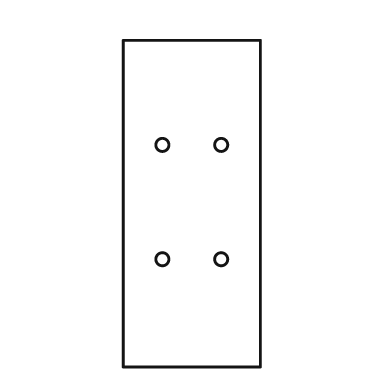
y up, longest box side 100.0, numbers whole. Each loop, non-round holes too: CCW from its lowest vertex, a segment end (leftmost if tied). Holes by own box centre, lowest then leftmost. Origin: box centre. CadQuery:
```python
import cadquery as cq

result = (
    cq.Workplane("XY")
    .moveTo(-21.0, -50.0)
    .lineTo(21.0, -50.0)
    .lineTo(21.0, 50.0)
    .lineTo(-21.0, 50.0)
    .close()
    .moveTo(-9.0, -17.0)
    .circle(2.0)
    .moveTo(9.0, -17.0)
    .circle(2.0)
    .moveTo(-9.0, 18.0)
    .circle(2.0)
    .moveTo(9.0, 18.0)
    .circle(2.0)
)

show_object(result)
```